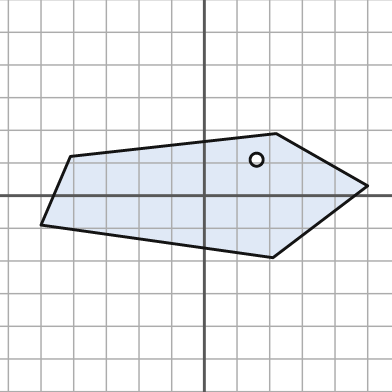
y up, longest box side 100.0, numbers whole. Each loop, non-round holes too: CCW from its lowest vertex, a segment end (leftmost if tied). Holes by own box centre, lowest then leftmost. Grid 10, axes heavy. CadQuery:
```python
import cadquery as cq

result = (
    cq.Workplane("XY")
    .moveTo(21.0, -19.0)
    .lineTo(50.0, 3.0)
    .lineTo(22.0, 19.0)
    .lineTo(-41.0, 12.0)
    .lineTo(-50.0, -9.0)
    .close()
    .moveTo(16.0, 11.0)
    .circle(2.0)
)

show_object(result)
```